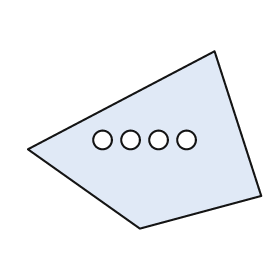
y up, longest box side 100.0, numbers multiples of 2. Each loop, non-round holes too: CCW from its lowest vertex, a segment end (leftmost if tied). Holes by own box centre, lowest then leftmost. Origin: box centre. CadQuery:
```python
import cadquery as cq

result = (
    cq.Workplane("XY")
    .moveTo(-2.0, -38.0)
    .lineTo(50.0, -24.0)
    .lineTo(30.0, 38.0)
    .lineTo(-50.0, -4.0)
    .close()
    .moveTo(-18.0, 0.0)
    .circle(4.0)
    .moveTo(-6.0, 0.0)
    .circle(4.0)
    .moveTo(6.0, 0.0)
    .circle(4.0)
    .moveTo(18.0, 0.0)
    .circle(4.0)
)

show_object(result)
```